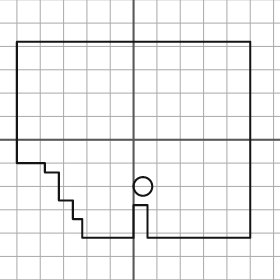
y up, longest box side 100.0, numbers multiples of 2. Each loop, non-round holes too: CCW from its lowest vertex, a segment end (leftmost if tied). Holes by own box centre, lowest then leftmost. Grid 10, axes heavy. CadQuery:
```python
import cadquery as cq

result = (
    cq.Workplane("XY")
    .moveTo(-22.0, -42.0)
    .lineTo(0.0, -42.0)
    .lineTo(0.0, -28.0)
    .lineTo(6.0, -28.0)
    .lineTo(6.0, -42.0)
    .lineTo(50.0, -42.0)
    .lineTo(50.0, 42.0)
    .lineTo(-50.0, 42.0)
    .lineTo(-50.0, -10.0)
    .lineTo(-38.0, -10.0)
    .lineTo(-38.0, -14.0)
    .lineTo(-32.0, -14.0)
    .lineTo(-32.0, -26.0)
    .lineTo(-26.0, -26.0)
    .lineTo(-26.0, -34.0)
    .lineTo(-22.0, -34.0)
    .close()
    .moveTo(4.0, -20.0)
    .circle(4.0)
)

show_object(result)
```